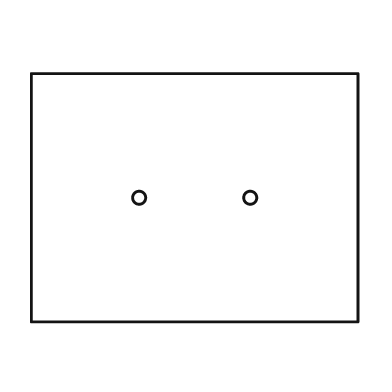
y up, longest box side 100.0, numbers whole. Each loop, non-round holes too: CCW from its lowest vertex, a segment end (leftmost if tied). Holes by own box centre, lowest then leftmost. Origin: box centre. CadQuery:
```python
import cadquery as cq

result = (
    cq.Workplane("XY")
    .moveTo(-50.0, -38.0)
    .lineTo(50.0, -38.0)
    .lineTo(50.0, 38.0)
    .lineTo(-50.0, 38.0)
    .close()
    .moveTo(-17.0, 0.0)
    .circle(2.0)
    .moveTo(17.0, 0.0)
    .circle(2.0)
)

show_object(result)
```